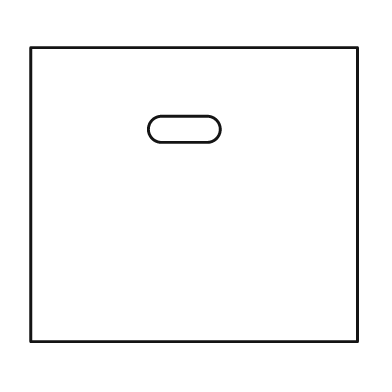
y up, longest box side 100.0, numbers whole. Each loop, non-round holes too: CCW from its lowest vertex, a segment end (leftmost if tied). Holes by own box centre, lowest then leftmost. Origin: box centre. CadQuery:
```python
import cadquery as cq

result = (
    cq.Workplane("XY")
    .moveTo(-50.0, -45.0)
    .lineTo(50.0, -45.0)
    .lineTo(50.0, 45.0)
    .lineTo(-50.0, 45.0)
    .close()
    .moveTo(-10.0, 16.0)
    .lineTo(4.0, 16.0)
    .threePointArc((8.0, 20.0), (4.0, 24.0))
    .lineTo(-10.0, 24.0)
    .threePointArc((-14.0, 20.0), (-10.0, 16.0))
    .close()
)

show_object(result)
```